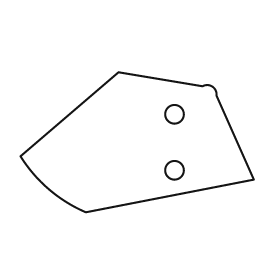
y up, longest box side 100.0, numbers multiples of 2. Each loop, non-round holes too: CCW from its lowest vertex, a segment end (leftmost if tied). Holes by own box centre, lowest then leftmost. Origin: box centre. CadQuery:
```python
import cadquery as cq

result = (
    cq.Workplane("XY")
    .moveTo(-22.0, -30.0)
    .lineTo(50.0, -16.0)
    .lineTo(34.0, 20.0)
    .threePointArc((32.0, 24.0), (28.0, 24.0))
    .lineTo(-8.0, 30.0)
    .lineTo(-50.0, -6.0)
    .threePointArc((-38.0, -20.0), (-22.0, -30.0))
    .close()
    .moveTo(16.0, -12.0)
    .circle(4.0)
    .moveTo(16.0, 12.0)
    .circle(4.0)
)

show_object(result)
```